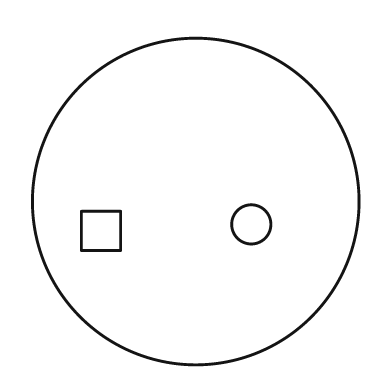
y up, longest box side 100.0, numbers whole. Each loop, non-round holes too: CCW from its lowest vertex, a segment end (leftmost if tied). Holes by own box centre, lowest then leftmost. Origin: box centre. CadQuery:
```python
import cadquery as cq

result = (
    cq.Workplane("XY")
    .moveTo(0.0, 0.0)
    .circle(50.0)
    .moveTo(-35.0, -15.0)
    .lineTo(-23.0, -15.0)
    .lineTo(-23.0, -3.0)
    .lineTo(-35.0, -3.0)
    .close()
    .moveTo(17.0, -7.0)
    .circle(6.0)
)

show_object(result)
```